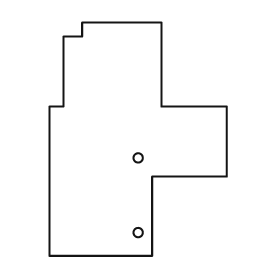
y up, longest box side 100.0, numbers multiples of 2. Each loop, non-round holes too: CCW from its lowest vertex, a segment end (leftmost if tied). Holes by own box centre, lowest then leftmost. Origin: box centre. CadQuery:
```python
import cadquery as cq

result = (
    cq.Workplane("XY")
    .moveTo(-38.0, -50.0)
    .lineTo(6.0, -50.0)
    .lineTo(6.0, -16.0)
    .lineTo(38.0, -16.0)
    .lineTo(38.0, 14.0)
    .lineTo(10.0, 14.0)
    .lineTo(10.0, 50.0)
    .lineTo(-24.0, 50.0)
    .lineTo(-24.0, 44.0)
    .lineTo(-32.0, 44.0)
    .lineTo(-32.0, 14.0)
    .lineTo(-38.0, 14.0)
    .close()
    .moveTo(0.0, -40.0)
    .circle(2.0)
    .moveTo(0.0, -8.0)
    .circle(2.0)
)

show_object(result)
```